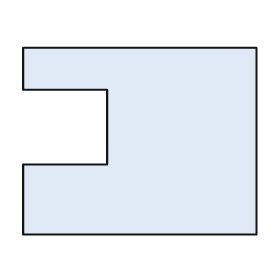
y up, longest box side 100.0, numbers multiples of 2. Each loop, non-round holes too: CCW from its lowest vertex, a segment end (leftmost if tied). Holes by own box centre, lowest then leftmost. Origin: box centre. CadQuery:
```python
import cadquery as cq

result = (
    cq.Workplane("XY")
    .moveTo(-50.0, -40.0)
    .lineTo(50.0, -40.0)
    .lineTo(50.0, 40.0)
    .lineTo(-50.0, 40.0)
    .lineTo(-50.0, 22.0)
    .lineTo(-14.0, 22.0)
    .lineTo(-14.0, -10.0)
    .lineTo(-50.0, -10.0)
    .close()
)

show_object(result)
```